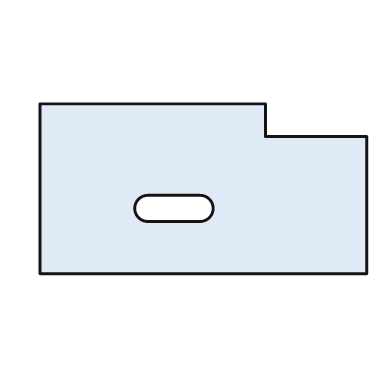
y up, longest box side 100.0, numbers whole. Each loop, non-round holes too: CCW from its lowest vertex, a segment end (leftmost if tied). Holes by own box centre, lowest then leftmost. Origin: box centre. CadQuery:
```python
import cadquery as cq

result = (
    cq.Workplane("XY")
    .moveTo(-50.0, -26.0)
    .lineTo(50.0, -26.0)
    .lineTo(50.0, 16.0)
    .lineTo(19.0, 16.0)
    .lineTo(19.0, 26.0)
    .lineTo(-50.0, 26.0)
    .close()
    .moveTo(-17.0, -10.0)
    .lineTo(-1.0, -10.0)
    .threePointArc((3.0, -6.0), (-1.0, -2.0))
    .lineTo(-17.0, -2.0)
    .threePointArc((-21.0, -6.0), (-17.0, -10.0))
    .close()
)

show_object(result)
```